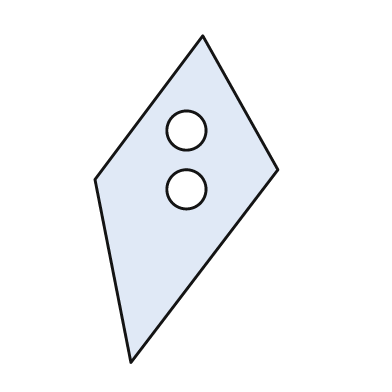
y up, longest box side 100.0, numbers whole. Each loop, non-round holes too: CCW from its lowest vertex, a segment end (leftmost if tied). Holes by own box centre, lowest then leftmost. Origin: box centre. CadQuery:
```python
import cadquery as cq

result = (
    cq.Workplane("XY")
    .moveTo(-17.0, -50.0)
    .lineTo(28.0, 9.0)
    .lineTo(5.0, 50.0)
    .lineTo(-28.0, 6.0)
    .close()
    .moveTo(0.0, 3.0)
    .circle(6.0)
    .moveTo(0.0, 21.0)
    .circle(6.0)
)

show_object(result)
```